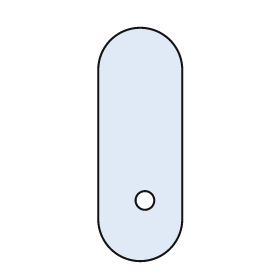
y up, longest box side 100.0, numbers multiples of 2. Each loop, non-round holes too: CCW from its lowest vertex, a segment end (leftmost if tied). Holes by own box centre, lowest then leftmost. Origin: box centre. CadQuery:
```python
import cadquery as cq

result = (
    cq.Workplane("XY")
    .moveTo(-18.0, -32.0)
    .threePointArc((0.0, -50.0), (18.0, -32.0))
    .lineTo(18.0, 32.0)
    .threePointArc((0.0, 50.0), (-18.0, 32.0))
    .close()
    .moveTo(2.0, -24.0)
    .circle(4.0)
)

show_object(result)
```